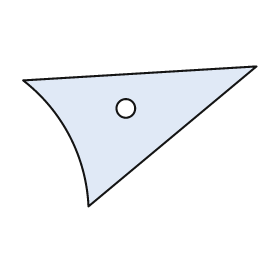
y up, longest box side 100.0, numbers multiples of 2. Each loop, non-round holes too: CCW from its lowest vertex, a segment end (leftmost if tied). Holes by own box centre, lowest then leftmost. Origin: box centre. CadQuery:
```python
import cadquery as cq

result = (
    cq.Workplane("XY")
    .moveTo(-22.0, -30.0)
    .lineTo(50.0, 30.0)
    .lineTo(-50.0, 24.0)
    .threePointArc((-30.0, 0.0), (-22.0, -30.0))
    .close()
    .moveTo(-6.0, 12.0)
    .circle(4.0)
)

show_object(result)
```